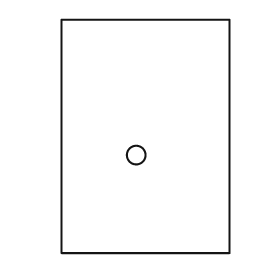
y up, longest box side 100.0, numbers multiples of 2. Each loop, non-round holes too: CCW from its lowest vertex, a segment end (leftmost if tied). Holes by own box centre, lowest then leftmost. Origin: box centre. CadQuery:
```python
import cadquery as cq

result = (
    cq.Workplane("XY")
    .moveTo(-36.0, -50.0)
    .lineTo(36.0, -50.0)
    .lineTo(36.0, 50.0)
    .lineTo(-36.0, 50.0)
    .close()
    .moveTo(-4.0, -8.0)
    .circle(4.0)
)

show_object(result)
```